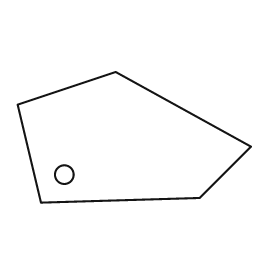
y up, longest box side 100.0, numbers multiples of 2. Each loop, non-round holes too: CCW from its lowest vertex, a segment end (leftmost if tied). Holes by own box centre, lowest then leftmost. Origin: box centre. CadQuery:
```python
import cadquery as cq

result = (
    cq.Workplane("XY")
    .moveTo(-40.0, -28.0)
    .lineTo(28.0, -26.0)
    .lineTo(50.0, -4.0)
    .lineTo(-8.0, 28.0)
    .lineTo(-50.0, 14.0)
    .close()
    .moveTo(-30.0, -16.0)
    .circle(4.0)
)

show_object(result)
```